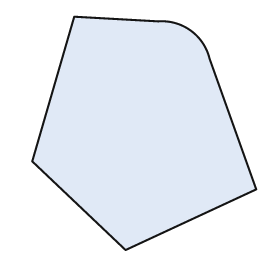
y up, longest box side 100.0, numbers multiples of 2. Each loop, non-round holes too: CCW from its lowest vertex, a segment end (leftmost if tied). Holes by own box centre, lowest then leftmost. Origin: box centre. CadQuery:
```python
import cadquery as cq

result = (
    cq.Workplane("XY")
    .moveTo(-8.0, -50.0)
    .lineTo(48.0, -24.0)
    .lineTo(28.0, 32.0)
    .threePointArc((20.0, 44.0), (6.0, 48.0))
    .lineTo(-30.0, 50.0)
    .lineTo(-48.0, -12.0)
    .close()
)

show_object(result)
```